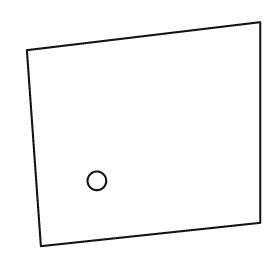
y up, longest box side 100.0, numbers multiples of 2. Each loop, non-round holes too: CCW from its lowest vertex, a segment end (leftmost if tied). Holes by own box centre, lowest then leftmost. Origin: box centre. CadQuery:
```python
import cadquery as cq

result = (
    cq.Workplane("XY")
    .moveTo(-44.0, -48.0)
    .lineTo(50.0, -38.0)
    .lineTo(50.0, 48.0)
    .lineTo(-50.0, 36.0)
    .close()
    .moveTo(-20.0, -20.0)
    .circle(4.0)
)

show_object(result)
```